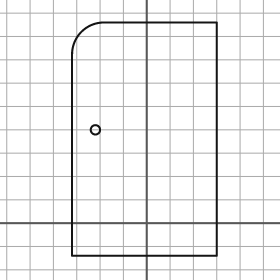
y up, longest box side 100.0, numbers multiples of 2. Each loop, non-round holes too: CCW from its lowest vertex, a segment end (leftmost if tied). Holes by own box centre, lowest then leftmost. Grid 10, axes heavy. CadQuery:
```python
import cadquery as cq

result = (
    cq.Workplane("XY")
    .moveTo(-32.0, -14.0)
    .lineTo(30.0, -14.0)
    .lineTo(30.0, 86.0)
    .lineTo(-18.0, 86.0)
    .threePointArc((-28.0, 82.0), (-32.0, 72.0))
    .close()
    .moveTo(-22.0, 40.0)
    .circle(2.0)
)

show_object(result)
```